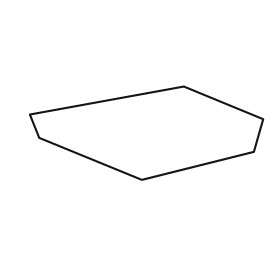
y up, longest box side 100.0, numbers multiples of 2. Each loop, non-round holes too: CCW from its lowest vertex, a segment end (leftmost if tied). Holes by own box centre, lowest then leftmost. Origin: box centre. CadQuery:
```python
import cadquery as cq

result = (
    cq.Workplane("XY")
    .moveTo(-2.0, -20.0)
    .lineTo(46.0, -8.0)
    .lineTo(50.0, 6.0)
    .lineTo(16.0, 20.0)
    .lineTo(-50.0, 8.0)
    .lineTo(-46.0, -2.0)
    .close()
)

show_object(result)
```